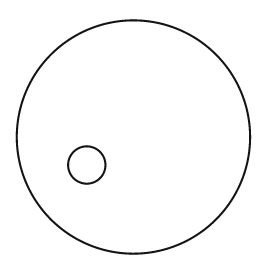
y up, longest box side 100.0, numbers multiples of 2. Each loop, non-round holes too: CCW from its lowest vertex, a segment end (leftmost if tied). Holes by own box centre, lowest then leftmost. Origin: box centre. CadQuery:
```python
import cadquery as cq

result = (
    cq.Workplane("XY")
    .moveTo(0.0, 0.0)
    .circle(50.0)
    .moveTo(-20.0, -12.0)
    .circle(8.0)
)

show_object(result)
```